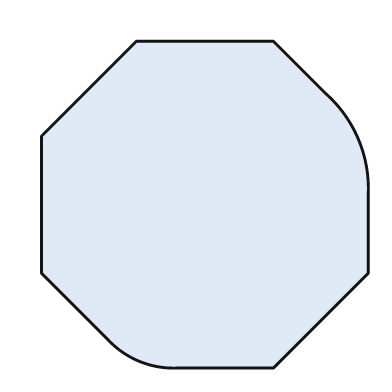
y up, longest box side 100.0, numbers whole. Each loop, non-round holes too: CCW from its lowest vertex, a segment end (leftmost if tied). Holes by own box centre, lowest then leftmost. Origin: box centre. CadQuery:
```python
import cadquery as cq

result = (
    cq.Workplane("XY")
    .moveTo(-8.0, -50.0)
    .lineTo(21.0, -50.0)
    .lineTo(50.0, -21.0)
    .lineTo(50.0, 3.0)
    .threePointArc((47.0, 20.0), (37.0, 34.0))
    .lineTo(21.0, 50.0)
    .lineTo(-21.0, 50.0)
    .lineTo(-50.0, 21.0)
    .lineTo(-50.0, -21.0)
    .lineTo(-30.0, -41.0)
    .threePointArc((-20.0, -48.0), (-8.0, -50.0))
    .close()
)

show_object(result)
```